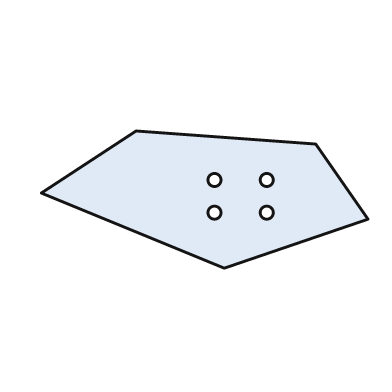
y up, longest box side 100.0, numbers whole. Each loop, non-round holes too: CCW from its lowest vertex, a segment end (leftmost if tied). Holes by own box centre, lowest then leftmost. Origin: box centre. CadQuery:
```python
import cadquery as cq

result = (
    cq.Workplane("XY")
    .moveTo(6.0, -21.0)
    .lineTo(50.0, -6.0)
    .lineTo(34.0, 17.0)
    .lineTo(-21.0, 21.0)
    .lineTo(-50.0, 2.0)
    .close()
    .moveTo(3.0, -4.0)
    .circle(2.0)
    .moveTo(19.0, -4.0)
    .circle(2.0)
    .moveTo(3.0, 6.0)
    .circle(2.0)
    .moveTo(19.0, 6.0)
    .circle(2.0)
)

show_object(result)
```